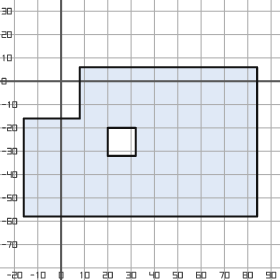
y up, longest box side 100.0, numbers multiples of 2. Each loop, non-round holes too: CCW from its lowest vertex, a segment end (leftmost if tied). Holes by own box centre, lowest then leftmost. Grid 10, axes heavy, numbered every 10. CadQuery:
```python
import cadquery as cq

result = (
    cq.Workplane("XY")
    .moveTo(-16.0, -58.0)
    .lineTo(84.0, -58.0)
    .lineTo(84.0, 6.0)
    .lineTo(8.0, 6.0)
    .lineTo(8.0, -16.0)
    .lineTo(-16.0, -16.0)
    .close()
    .moveTo(20.0, -32.0)
    .lineTo(32.0, -32.0)
    .lineTo(32.0, -20.0)
    .lineTo(20.0, -20.0)
    .close()
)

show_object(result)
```